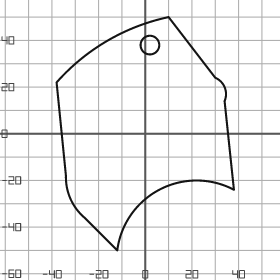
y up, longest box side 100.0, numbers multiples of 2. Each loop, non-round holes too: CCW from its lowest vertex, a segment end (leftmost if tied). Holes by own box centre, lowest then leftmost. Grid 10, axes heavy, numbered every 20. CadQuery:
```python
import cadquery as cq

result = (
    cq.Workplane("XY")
    .moveTo(-12.0, -50.0)
    .threePointArc((6.0, -24.0), (38.0, -24.0))
    .lineTo(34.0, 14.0)
    .threePointArc((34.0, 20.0), (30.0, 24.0))
    .lineTo(10.0, 50.0)
    .threePointArc((-16.0, 40.0), (-38.0, 22.0))
    .lineTo(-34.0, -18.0)
    .threePointArc((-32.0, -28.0), (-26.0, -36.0))
    .close()
    .moveTo(2.0, 38.0)
    .circle(4.0)
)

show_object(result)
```